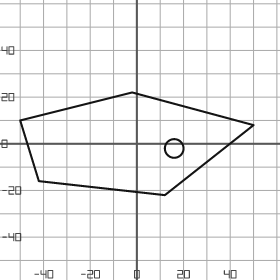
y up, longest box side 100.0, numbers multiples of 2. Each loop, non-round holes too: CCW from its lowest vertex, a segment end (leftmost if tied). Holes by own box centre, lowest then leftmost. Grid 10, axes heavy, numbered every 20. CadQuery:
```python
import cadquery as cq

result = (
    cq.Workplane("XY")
    .moveTo(12.0, -22.0)
    .lineTo(50.0, 8.0)
    .lineTo(-2.0, 22.0)
    .lineTo(-50.0, 10.0)
    .lineTo(-42.0, -16.0)
    .close()
    .moveTo(16.0, -2.0)
    .circle(4.0)
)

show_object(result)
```